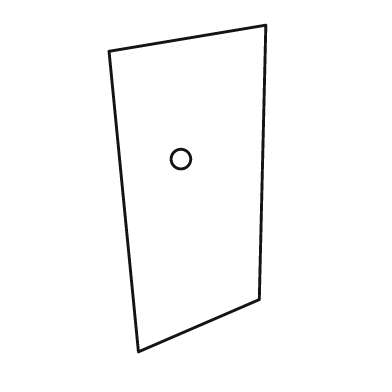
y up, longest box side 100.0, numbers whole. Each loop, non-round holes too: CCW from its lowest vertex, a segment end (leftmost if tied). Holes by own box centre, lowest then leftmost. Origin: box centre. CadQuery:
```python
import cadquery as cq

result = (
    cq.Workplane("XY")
    .moveTo(-15.0, -50.0)
    .lineTo(22.0, -34.0)
    .lineTo(24.0, 50.0)
    .lineTo(-24.0, 42.0)
    .close()
    .moveTo(-2.0, 9.0)
    .circle(3.0)
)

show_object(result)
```